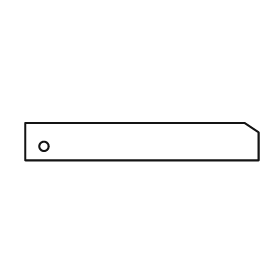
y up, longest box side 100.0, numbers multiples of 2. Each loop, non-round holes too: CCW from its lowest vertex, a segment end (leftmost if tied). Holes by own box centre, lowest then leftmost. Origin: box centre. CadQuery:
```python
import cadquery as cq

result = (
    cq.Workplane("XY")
    .moveTo(-50.0, -8.0)
    .lineTo(50.0, -8.0)
    .lineTo(50.0, 4.0)
    .lineTo(44.0, 8.0)
    .lineTo(-50.0, 8.0)
    .close()
    .moveTo(-42.0, -2.0)
    .circle(2.0)
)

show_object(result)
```